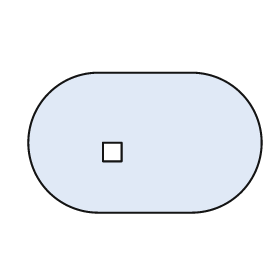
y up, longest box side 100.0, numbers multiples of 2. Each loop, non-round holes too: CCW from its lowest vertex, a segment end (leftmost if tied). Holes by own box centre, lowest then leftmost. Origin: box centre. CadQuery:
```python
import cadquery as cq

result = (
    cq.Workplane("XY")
    .moveTo(-20.0, -30.0)
    .lineTo(20.0, -30.0)
    .threePointArc((50.0, 0.0), (20.0, 30.0))
    .lineTo(-20.0, 30.0)
    .threePointArc((-50.0, 0.0), (-20.0, -30.0))
    .close()
    .moveTo(-18.0, -8.0)
    .lineTo(-10.0, -8.0)
    .lineTo(-10.0, 0.0)
    .lineTo(-18.0, 0.0)
    .close()
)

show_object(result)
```